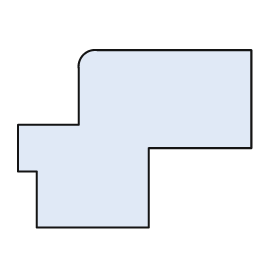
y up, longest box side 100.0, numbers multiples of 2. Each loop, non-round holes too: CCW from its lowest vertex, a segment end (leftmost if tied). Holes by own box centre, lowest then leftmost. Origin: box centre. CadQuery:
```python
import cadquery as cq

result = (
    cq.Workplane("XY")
    .moveTo(-42.0, -38.0)
    .lineTo(6.0, -38.0)
    .lineTo(6.0, -4.0)
    .lineTo(50.0, -4.0)
    .lineTo(50.0, 38.0)
    .lineTo(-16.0, 38.0)
    .threePointArc((-22.0, 36.0), (-24.0, 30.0))
    .lineTo(-24.0, 6.0)
    .lineTo(-50.0, 6.0)
    .lineTo(-50.0, -14.0)
    .lineTo(-42.0, -14.0)
    .close()
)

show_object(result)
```